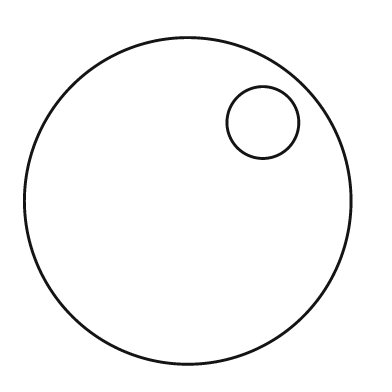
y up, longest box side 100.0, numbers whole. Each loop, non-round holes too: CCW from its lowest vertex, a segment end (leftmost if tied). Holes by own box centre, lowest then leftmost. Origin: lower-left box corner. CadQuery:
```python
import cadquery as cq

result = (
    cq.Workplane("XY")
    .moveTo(50.0, 50.0)
    .circle(50.0)
    .moveTo(73.0, 74.0)
    .circle(11.0)
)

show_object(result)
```